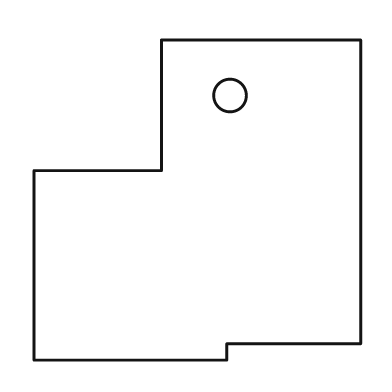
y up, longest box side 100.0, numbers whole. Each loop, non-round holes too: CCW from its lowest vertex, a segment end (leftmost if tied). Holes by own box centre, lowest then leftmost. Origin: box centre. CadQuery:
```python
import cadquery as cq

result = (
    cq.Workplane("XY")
    .moveTo(-50.0, -49.0)
    .lineTo(9.0, -49.0)
    .lineTo(9.0, -44.0)
    .lineTo(50.0, -44.0)
    .lineTo(50.0, 49.0)
    .lineTo(-11.0, 49.0)
    .lineTo(-11.0, 9.0)
    .lineTo(-50.0, 9.0)
    .close()
    .moveTo(10.0, 32.0)
    .circle(5.0)
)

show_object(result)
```